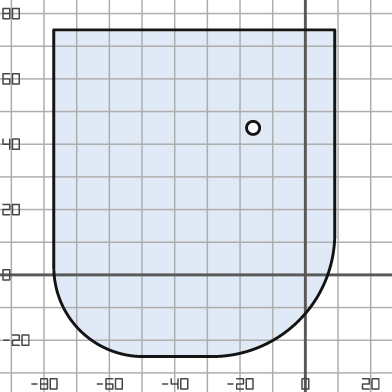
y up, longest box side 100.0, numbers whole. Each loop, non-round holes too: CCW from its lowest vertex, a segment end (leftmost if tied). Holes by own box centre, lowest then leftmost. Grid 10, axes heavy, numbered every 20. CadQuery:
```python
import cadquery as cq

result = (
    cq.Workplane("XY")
    .moveTo(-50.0, -25.0)
    .lineTo(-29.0, -25.0)
    .threePointArc((-2.0, -14.0), (9.0, 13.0))
    .lineTo(9.0, 75.0)
    .lineTo(-77.0, 75.0)
    .lineTo(-77.0, 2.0)
    .threePointArc((-69.0, -17.0), (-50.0, -25.0))
    .close()
    .moveTo(-16.0, 45.0)
    .circle(2.0)
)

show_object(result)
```